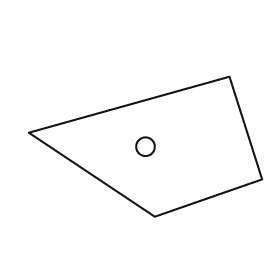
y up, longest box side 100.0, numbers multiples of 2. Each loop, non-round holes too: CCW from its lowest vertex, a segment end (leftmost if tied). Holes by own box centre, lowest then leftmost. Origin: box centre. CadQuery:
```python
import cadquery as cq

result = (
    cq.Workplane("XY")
    .moveTo(4.0, -30.0)
    .lineTo(50.0, -14.0)
    .lineTo(36.0, 30.0)
    .lineTo(-50.0, 6.0)
    .close()
    .moveTo(0.0, 0.0)
    .circle(4.0)
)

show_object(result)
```